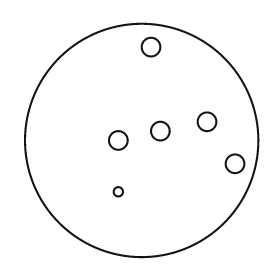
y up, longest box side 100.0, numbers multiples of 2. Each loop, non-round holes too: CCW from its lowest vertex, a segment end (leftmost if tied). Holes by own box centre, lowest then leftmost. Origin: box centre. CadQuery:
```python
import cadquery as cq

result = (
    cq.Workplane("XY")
    .moveTo(0.0, 0.0)
    .circle(50.0)
    .moveTo(-10.0, -22.0)
    .circle(2.0)
    .moveTo(40.0, -10.0)
    .circle(4.0)
    .moveTo(-10.0, 0.0)
    .circle(4.0)
    .moveTo(8.0, 4.0)
    .circle(4.0)
    .moveTo(28.0, 8.0)
    .circle(4.0)
    .moveTo(4.0, 40.0)
    .circle(4.0)
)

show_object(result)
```